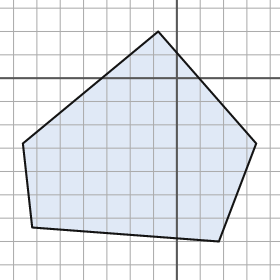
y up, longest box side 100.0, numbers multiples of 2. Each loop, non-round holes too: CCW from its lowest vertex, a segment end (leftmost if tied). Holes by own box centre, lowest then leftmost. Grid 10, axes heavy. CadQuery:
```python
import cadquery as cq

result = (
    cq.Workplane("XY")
    .moveTo(18.0, -70.0)
    .lineTo(34.0, -28.0)
    .lineTo(-8.0, 20.0)
    .lineTo(-66.0, -28.0)
    .lineTo(-62.0, -64.0)
    .close()
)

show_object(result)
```